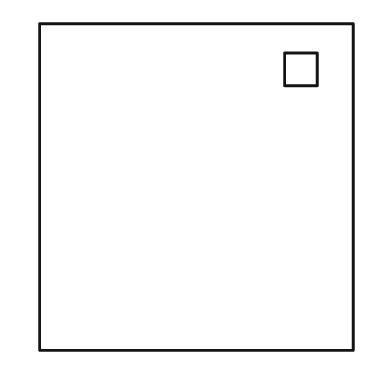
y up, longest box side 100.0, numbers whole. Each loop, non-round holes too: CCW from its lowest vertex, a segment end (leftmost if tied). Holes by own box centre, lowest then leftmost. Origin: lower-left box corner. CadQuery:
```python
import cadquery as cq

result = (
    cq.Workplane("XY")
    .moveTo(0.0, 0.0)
    .lineTo(96.0, 0.0)
    .lineTo(96.0, 100.0)
    .lineTo(0.0, 100.0)
    .close()
    .moveTo(75.0, 81.0)
    .lineTo(85.0, 81.0)
    .lineTo(85.0, 91.0)
    .lineTo(75.0, 91.0)
    .close()
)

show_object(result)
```